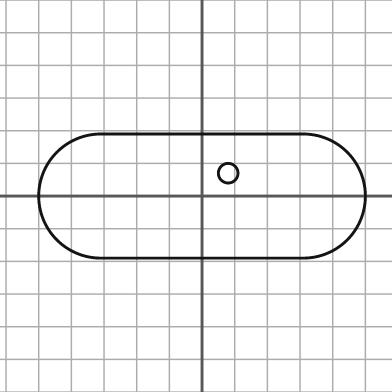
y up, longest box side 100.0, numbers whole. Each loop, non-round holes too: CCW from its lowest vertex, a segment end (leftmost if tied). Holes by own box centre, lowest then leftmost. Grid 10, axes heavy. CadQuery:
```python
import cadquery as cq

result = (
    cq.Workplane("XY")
    .moveTo(-31.0, -19.0)
    .lineTo(31.0, -19.0)
    .threePointArc((50.0, 0.0), (31.0, 19.0))
    .lineTo(-31.0, 19.0)
    .threePointArc((-50.0, 0.0), (-31.0, -19.0))
    .close()
    .moveTo(8.0, 7.0)
    .circle(3.0)
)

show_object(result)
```